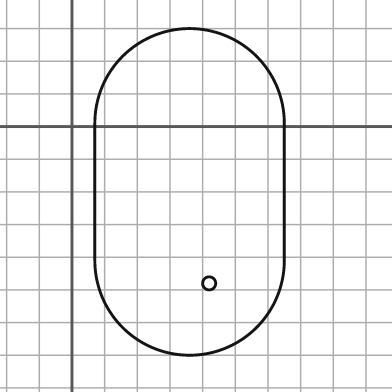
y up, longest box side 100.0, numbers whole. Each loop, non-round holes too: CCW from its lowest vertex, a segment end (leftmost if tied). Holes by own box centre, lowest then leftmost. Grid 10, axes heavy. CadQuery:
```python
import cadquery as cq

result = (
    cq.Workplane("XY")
    .moveTo(7.0, -41.0)
    .threePointArc((36.0, -70.0), (65.0, -41.0))
    .lineTo(65.0, 1.0)
    .threePointArc((36.0, 30.0), (7.0, 1.0))
    .close()
    .moveTo(42.0, -48.0)
    .circle(2.0)
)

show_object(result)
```